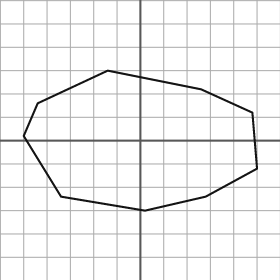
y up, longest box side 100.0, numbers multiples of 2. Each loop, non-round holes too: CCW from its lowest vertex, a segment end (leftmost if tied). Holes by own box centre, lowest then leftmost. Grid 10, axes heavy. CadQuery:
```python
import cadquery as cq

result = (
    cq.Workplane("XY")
    .moveTo(2.0, -30.0)
    .lineTo(28.0, -24.0)
    .lineTo(50.0, -12.0)
    .lineTo(48.0, 12.0)
    .lineTo(26.0, 22.0)
    .lineTo(-14.0, 30.0)
    .lineTo(-44.0, 16.0)
    .lineTo(-50.0, 2.0)
    .lineTo(-34.0, -24.0)
    .close()
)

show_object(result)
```